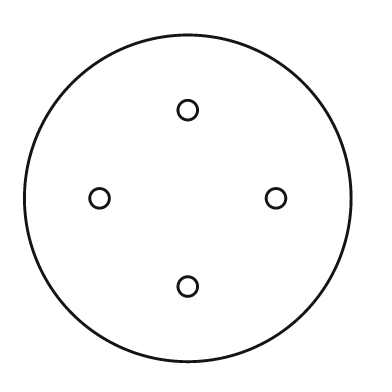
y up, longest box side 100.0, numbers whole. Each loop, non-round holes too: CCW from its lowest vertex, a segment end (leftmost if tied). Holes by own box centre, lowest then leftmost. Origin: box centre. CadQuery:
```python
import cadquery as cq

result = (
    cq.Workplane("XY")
    .moveTo(0.0, 0.0)
    .circle(50.0)
    .moveTo(0.0, -27.0)
    .circle(3.0)
    .moveTo(-27.0, 0.0)
    .circle(3.0)
    .moveTo(27.0, 0.0)
    .circle(3.0)
    .moveTo(0.0, 27.0)
    .circle(3.0)
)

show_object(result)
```